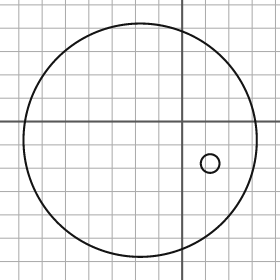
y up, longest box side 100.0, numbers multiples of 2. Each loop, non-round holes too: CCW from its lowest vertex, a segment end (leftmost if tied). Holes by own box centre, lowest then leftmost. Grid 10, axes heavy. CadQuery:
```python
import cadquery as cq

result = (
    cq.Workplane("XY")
    .moveTo(-18.0, -8.0)
    .circle(50.0)
    .moveTo(12.0, -18.0)
    .circle(4.0)
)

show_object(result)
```